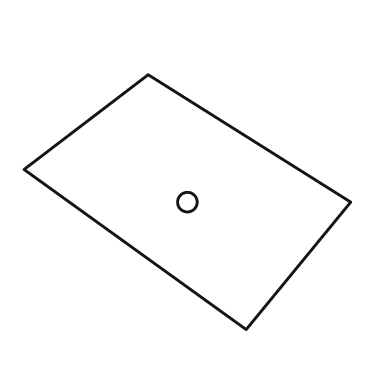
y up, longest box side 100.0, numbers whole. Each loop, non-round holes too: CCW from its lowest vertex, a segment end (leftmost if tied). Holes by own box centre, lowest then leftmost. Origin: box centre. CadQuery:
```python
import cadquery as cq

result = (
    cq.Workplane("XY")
    .moveTo(18.0, -39.0)
    .lineTo(50.0, 0.0)
    .lineTo(-12.0, 39.0)
    .lineTo(-50.0, 10.0)
    .close()
    .moveTo(0.0, 0.0)
    .circle(3.0)
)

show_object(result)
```